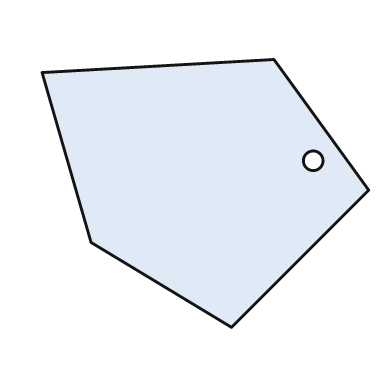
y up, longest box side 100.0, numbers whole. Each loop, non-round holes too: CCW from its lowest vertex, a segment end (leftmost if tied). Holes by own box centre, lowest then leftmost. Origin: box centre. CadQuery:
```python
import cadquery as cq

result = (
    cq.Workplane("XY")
    .moveTo(8.0, -41.0)
    .lineTo(50.0, 1.0)
    .lineTo(21.0, 41.0)
    .lineTo(-50.0, 37.0)
    .lineTo(-35.0, -15.0)
    .close()
    .moveTo(33.0, 10.0)
    .circle(3.0)
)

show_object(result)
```